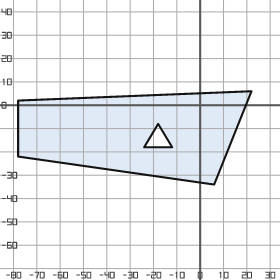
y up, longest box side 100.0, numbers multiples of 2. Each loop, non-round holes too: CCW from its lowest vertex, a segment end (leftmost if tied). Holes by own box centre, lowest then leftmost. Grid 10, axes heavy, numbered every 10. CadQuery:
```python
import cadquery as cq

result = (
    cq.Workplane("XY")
    .moveTo(6.0, -34.0)
    .lineTo(22.0, 6.0)
    .lineTo(-78.0, 2.0)
    .lineTo(-78.0, -22.0)
    .close()
    .moveTo(-24.0, -18.0)
    .lineTo(-12.0, -18.0)
    .lineTo(-18.0, -8.0)
    .close()
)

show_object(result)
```